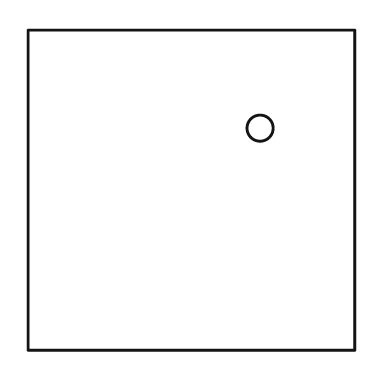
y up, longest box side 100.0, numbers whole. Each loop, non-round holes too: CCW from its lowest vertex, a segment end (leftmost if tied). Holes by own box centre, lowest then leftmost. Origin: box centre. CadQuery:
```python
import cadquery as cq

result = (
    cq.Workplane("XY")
    .moveTo(-50.0, -49.0)
    .lineTo(50.0, -49.0)
    .lineTo(50.0, 49.0)
    .lineTo(-50.0, 49.0)
    .close()
    .moveTo(21.0, 19.0)
    .circle(4.0)
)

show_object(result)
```